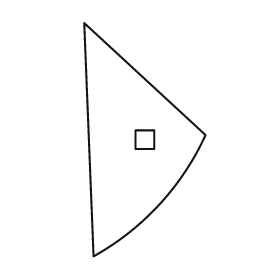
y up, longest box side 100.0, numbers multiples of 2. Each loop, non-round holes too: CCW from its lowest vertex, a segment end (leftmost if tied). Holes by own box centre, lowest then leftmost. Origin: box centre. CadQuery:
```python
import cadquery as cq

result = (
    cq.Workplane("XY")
    .moveTo(-22.0, -50.0)
    .threePointArc((6.0, -28.0), (26.0, 2.0))
    .lineTo(-26.0, 50.0)
    .close()
    .moveTo(-4.0, -4.0)
    .lineTo(4.0, -4.0)
    .lineTo(4.0, 4.0)
    .lineTo(-4.0, 4.0)
    .close()
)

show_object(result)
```